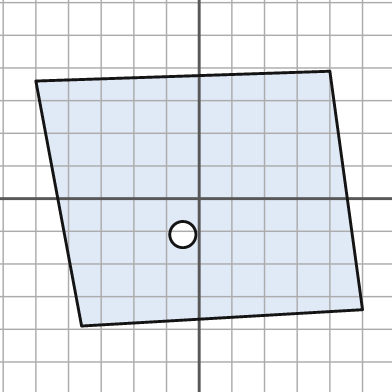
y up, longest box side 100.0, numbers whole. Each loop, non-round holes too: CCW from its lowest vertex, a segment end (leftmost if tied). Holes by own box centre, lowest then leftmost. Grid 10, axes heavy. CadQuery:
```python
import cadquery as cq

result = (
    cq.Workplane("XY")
    .moveTo(-36.0, -39.0)
    .lineTo(50.0, -34.0)
    .lineTo(40.0, 39.0)
    .lineTo(-50.0, 36.0)
    .close()
    .moveTo(-5.0, -11.0)
    .circle(4.0)
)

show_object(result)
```